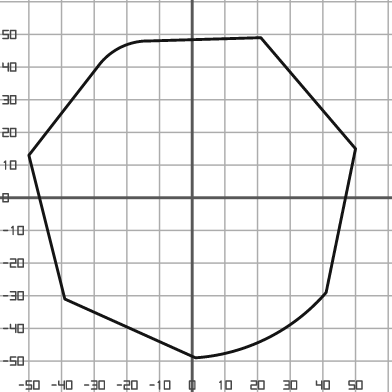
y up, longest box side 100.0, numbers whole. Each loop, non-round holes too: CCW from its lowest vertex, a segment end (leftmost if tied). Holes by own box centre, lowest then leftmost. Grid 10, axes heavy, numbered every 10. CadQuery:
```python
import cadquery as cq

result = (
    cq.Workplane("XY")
    .moveTo(1.0, -49.0)
    .threePointArc((23.0, -43.0), (41.0, -29.0))
    .lineTo(50.0, 15.0)
    .lineTo(21.0, 49.0)
    .lineTo(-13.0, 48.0)
    .threePointArc((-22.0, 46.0), (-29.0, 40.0))
    .lineTo(-50.0, 13.0)
    .lineTo(-39.0, -31.0)
    .close()
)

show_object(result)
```